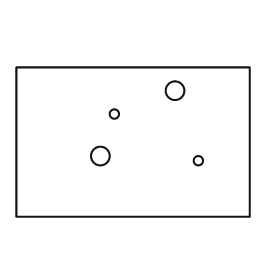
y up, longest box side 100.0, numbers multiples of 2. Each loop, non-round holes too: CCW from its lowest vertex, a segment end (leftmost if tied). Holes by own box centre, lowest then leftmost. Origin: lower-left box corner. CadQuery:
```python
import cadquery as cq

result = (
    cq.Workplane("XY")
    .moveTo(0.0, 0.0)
    .lineTo(100.0, 0.0)
    .lineTo(100.0, 64.0)
    .lineTo(0.0, 64.0)
    .close()
    .moveTo(78.0, 24.0)
    .circle(2.0)
    .moveTo(36.0, 26.0)
    .circle(4.0)
    .moveTo(42.0, 44.0)
    .circle(2.0)
    .moveTo(68.0, 54.0)
    .circle(4.0)
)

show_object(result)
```